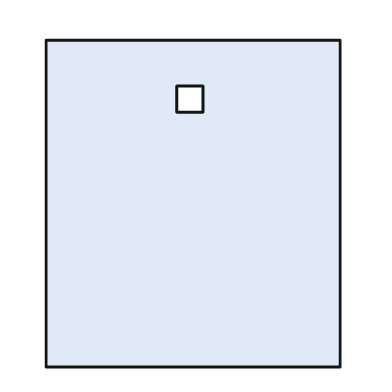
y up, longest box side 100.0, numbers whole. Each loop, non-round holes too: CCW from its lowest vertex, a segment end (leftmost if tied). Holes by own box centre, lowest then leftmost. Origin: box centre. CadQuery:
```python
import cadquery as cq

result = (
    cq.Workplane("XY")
    .moveTo(-45.0, -50.0)
    .lineTo(45.0, -50.0)
    .lineTo(45.0, 50.0)
    .lineTo(-45.0, 50.0)
    .close()
    .moveTo(-5.0, 28.0)
    .lineTo(3.0, 28.0)
    .lineTo(3.0, 36.0)
    .lineTo(-5.0, 36.0)
    .close()
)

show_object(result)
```